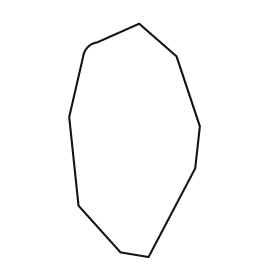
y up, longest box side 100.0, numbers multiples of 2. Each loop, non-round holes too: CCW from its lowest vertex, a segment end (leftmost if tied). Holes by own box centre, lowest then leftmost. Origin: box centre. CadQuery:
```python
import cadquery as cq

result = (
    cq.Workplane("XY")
    .moveTo(6.0, -50.0)
    .lineTo(26.0, -12.0)
    .lineTo(28.0, 6.0)
    .lineTo(18.0, 36.0)
    .lineTo(2.0, 50.0)
    .lineTo(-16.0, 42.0)
    .threePointArc((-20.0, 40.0), (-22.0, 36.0))
    .lineTo(-28.0, 10.0)
    .lineTo(-24.0, -28.0)
    .lineTo(-6.0, -48.0)
    .close()
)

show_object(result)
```